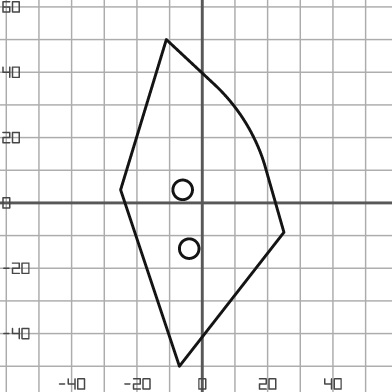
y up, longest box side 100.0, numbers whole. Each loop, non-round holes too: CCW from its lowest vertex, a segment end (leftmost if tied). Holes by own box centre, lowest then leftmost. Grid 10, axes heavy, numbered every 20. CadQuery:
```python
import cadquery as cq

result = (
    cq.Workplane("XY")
    .moveTo(-7.0, -50.0)
    .lineTo(25.0, -9.0)
    .lineTo(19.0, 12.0)
    .threePointArc((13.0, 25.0), (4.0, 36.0))
    .lineTo(-11.0, 50.0)
    .lineTo(-25.0, 4.0)
    .close()
    .moveTo(-4.0, -14.0)
    .circle(3.0)
    .moveTo(-6.0, 4.0)
    .circle(3.0)
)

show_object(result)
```